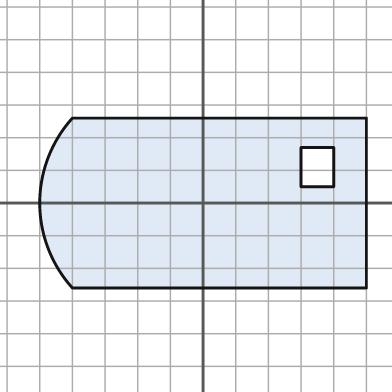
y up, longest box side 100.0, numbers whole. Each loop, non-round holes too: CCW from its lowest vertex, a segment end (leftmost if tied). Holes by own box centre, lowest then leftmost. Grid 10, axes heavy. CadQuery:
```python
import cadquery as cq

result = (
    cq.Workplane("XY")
    .moveTo(-40.0, -26.0)
    .lineTo(50.0, -26.0)
    .lineTo(50.0, 26.0)
    .lineTo(-40.0, 26.0)
    .threePointArc((-50.0, 0.0), (-40.0, -26.0))
    .close()
    .moveTo(30.0, 5.0)
    .lineTo(40.0, 5.0)
    .lineTo(40.0, 17.0)
    .lineTo(30.0, 17.0)
    .close()
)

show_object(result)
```